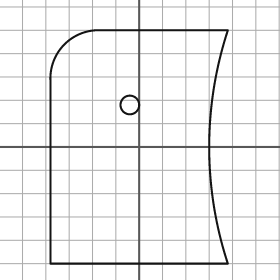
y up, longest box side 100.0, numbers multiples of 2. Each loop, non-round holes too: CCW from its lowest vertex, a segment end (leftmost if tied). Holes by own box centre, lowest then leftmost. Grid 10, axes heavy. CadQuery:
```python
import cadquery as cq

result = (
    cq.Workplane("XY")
    .moveTo(-38.0, -50.0)
    .lineTo(38.0, -50.0)
    .threePointArc((30.0, 0.0), (38.0, 50.0))
    .lineTo(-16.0, 50.0)
    .threePointArc((-32.0, 44.0), (-38.0, 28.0))
    .close()
    .moveTo(-4.0, 18.0)
    .circle(4.0)
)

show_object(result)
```